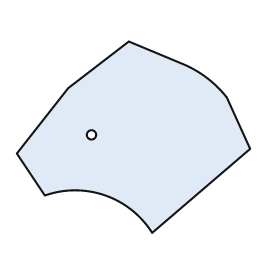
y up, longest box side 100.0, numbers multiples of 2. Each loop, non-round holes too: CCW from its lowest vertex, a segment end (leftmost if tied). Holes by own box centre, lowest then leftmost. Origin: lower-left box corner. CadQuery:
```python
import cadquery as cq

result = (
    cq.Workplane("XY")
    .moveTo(58.0, 0.0)
    .lineTo(100.0, 36.0)
    .lineTo(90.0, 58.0)
    .threePointArc((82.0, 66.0), (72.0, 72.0))
    .lineTo(48.0, 82.0)
    .lineTo(22.0, 62.0)
    .lineTo(0.0, 34.0)
    .lineTo(12.0, 16.0)
    .threePointArc((38.0, 16.0), (58.0, 0.0))
    .close()
    .moveTo(32.0, 42.0)
    .circle(2.0)
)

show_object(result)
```